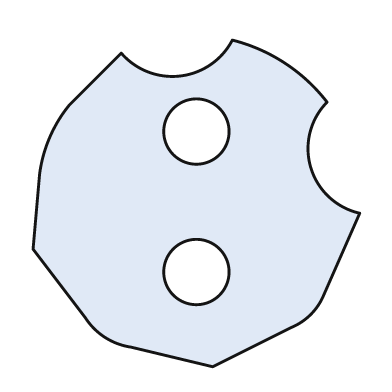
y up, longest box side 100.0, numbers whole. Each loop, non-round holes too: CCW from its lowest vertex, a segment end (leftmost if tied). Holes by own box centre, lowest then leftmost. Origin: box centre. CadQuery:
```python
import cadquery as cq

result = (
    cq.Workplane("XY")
    .moveTo(5.0, -50.0)
    .lineTo(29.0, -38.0)
    .threePointArc((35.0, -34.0), (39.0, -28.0))
    .lineTo(50.0, -3.0)
    .threePointArc((35.0, 11.0), (40.0, 31.0))
    .threePointArc((27.0, 43.0), (11.0, 50.0))
    .threePointArc((-5.0, 39.0), (-23.0, 46.0))
    .lineTo(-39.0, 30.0)
    .threePointArc((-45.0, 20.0), (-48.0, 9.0))
    .lineTo(-50.0, -14.0)
    .lineTo(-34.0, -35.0)
    .threePointArc((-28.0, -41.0), (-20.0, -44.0))
    .close()
    .moveTo(0.0, -21.0)
    .circle(10.0)
    .moveTo(0.0, 22.0)
    .circle(10.0)
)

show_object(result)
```